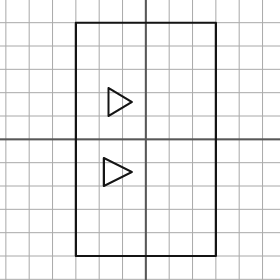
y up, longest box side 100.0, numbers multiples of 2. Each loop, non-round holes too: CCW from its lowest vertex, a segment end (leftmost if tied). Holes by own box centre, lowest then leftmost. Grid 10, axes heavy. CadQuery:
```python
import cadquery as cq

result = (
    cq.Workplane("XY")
    .moveTo(-30.0, -50.0)
    .lineTo(30.0, -50.0)
    .lineTo(30.0, 50.0)
    .lineTo(-30.0, 50.0)
    .close()
    .moveTo(-18.0, -20.0)
    .lineTo(-6.0, -14.0)
    .lineTo(-18.0, -8.0)
    .close()
    .moveTo(-16.0, 10.0)
    .lineTo(-6.0, 16.0)
    .lineTo(-16.0, 22.0)
    .close()
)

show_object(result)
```